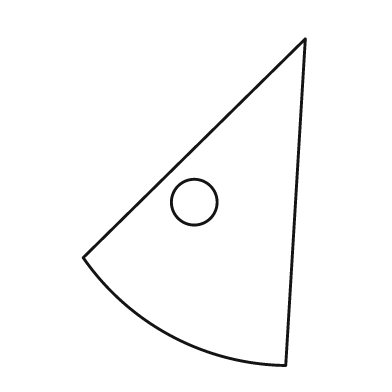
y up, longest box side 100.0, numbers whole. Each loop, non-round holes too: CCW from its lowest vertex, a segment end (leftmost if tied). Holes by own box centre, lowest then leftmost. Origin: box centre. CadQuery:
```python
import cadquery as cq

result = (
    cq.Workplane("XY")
    .moveTo(28.0, -50.0)
    .lineTo(34.0, 50.0)
    .lineTo(-34.0, -17.0)
    .threePointArc((-7.0, -41.0), (28.0, -50.0))
    .close()
    .moveTo(0.0, 0.0)
    .circle(7.0)
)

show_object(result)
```